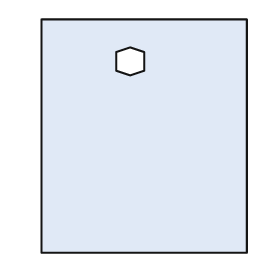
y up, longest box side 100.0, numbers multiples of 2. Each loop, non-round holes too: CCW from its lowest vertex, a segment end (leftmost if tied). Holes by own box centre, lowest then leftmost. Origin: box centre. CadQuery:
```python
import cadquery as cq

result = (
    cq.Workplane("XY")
    .moveTo(-44.0, -50.0)
    .lineTo(44.0, -50.0)
    .lineTo(44.0, 50.0)
    .lineTo(-44.0, 50.0)
    .close()
    .moveTo(-6.0, 26.0)
    .lineTo(0.0, 28.0)
    .lineTo(0.0, 36.0)
    .lineTo(-6.0, 38.0)
    .lineTo(-12.0, 36.0)
    .lineTo(-12.0, 28.0)
    .close()
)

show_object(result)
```